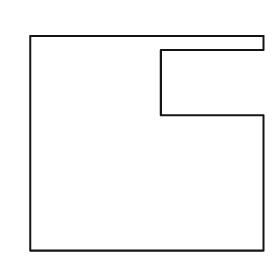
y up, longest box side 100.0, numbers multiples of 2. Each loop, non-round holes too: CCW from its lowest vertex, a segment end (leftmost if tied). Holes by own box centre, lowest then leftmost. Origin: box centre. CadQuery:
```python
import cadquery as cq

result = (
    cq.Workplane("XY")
    .moveTo(-50.0, -46.0)
    .lineTo(50.0, -46.0)
    .lineTo(50.0, 12.0)
    .lineTo(6.0, 12.0)
    .lineTo(6.0, 40.0)
    .lineTo(50.0, 40.0)
    .lineTo(50.0, 46.0)
    .lineTo(-50.0, 46.0)
    .close()
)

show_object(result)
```